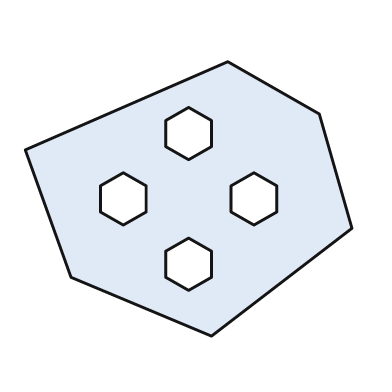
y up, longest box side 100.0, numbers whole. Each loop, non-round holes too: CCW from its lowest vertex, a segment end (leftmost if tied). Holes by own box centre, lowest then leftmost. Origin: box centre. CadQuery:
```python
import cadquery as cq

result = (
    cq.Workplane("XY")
    .moveTo(7.0, -42.0)
    .lineTo(50.0, -9.0)
    .lineTo(40.0, 26.0)
    .lineTo(12.0, 42.0)
    .lineTo(-50.0, 15.0)
    .lineTo(-36.0, -24.0)
    .close()
    .moveTo(0.0, -28.0)
    .lineTo(7.0, -24.0)
    .lineTo(7.0, -16.0)
    .lineTo(0.0, -12.0)
    .lineTo(-7.0, -16.0)
    .lineTo(-7.0, -24.0)
    .close()
    .moveTo(-20.0, -8.0)
    .lineTo(-13.0, -4.0)
    .lineTo(-13.0, 4.0)
    .lineTo(-20.0, 8.0)
    .lineTo(-27.0, 4.0)
    .lineTo(-27.0, -4.0)
    .close()
    .moveTo(20.0, -8.0)
    .lineTo(27.0, -4.0)
    .lineTo(27.0, 4.0)
    .lineTo(20.0, 8.0)
    .lineTo(13.0, 4.0)
    .lineTo(13.0, -4.0)
    .close()
    .moveTo(0.0, 12.0)
    .lineTo(7.0, 16.0)
    .lineTo(7.0, 24.0)
    .lineTo(0.0, 28.0)
    .lineTo(-7.0, 24.0)
    .lineTo(-7.0, 16.0)
    .close()
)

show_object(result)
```